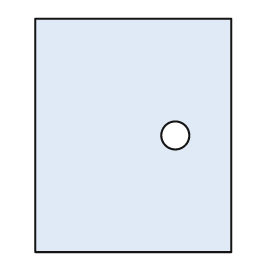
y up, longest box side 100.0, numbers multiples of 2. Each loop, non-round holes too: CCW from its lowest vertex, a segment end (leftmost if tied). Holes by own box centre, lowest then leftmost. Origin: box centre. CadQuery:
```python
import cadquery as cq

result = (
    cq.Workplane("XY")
    .moveTo(-42.0, -50.0)
    .lineTo(42.0, -50.0)
    .lineTo(42.0, 50.0)
    .lineTo(-42.0, 50.0)
    .close()
    .moveTo(18.0, 0.0)
    .circle(6.0)
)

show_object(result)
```